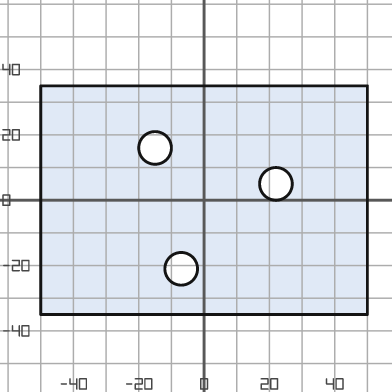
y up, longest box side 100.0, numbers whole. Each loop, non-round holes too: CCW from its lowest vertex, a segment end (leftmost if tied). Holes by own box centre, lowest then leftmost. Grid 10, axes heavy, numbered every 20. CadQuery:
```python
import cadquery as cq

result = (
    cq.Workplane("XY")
    .moveTo(-50.0, -35.0)
    .lineTo(50.0, -35.0)
    .lineTo(50.0, 35.0)
    .lineTo(-50.0, 35.0)
    .close()
    .moveTo(-7.0, -21.0)
    .circle(5.0)
    .moveTo(22.0, 5.0)
    .circle(5.0)
    .moveTo(-15.0, 16.0)
    .circle(5.0)
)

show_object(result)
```